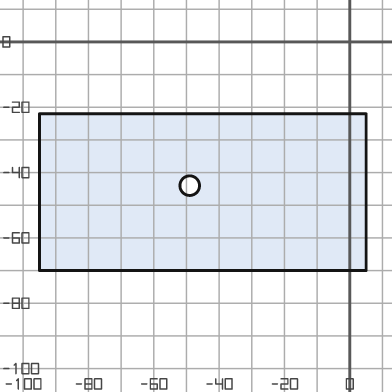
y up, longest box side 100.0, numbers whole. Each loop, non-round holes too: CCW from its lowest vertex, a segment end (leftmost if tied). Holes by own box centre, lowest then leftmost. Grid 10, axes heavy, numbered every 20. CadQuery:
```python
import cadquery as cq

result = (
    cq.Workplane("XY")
    .moveTo(-95.0, -70.0)
    .lineTo(5.0, -70.0)
    .lineTo(5.0, -22.0)
    .lineTo(-95.0, -22.0)
    .close()
    .moveTo(-49.0, -44.0)
    .circle(3.0)
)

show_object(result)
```